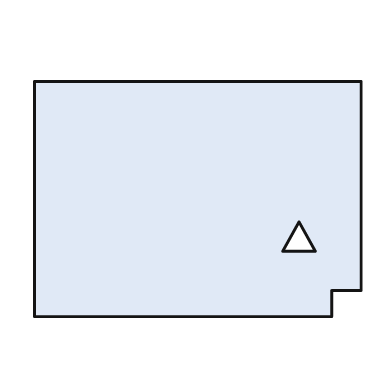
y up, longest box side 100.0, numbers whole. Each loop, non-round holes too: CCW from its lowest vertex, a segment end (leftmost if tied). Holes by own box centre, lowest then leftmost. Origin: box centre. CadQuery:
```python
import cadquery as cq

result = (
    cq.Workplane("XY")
    .moveTo(-50.0, -36.0)
    .lineTo(41.0, -36.0)
    .lineTo(41.0, -28.0)
    .lineTo(50.0, -28.0)
    .lineTo(50.0, 36.0)
    .lineTo(-50.0, 36.0)
    .close()
    .moveTo(26.0, -16.0)
    .lineTo(36.0, -16.0)
    .lineTo(31.0, -7.0)
    .close()
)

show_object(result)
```